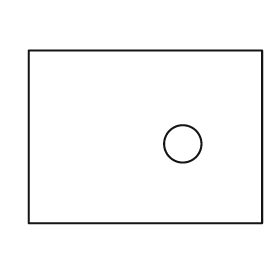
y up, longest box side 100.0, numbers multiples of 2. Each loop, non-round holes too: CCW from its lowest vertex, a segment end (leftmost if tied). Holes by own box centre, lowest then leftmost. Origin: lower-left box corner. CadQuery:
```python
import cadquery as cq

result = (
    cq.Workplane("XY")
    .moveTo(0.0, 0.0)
    .lineTo(100.0, 0.0)
    .lineTo(100.0, 74.0)
    .lineTo(0.0, 74.0)
    .close()
    .moveTo(66.0, 34.0)
    .circle(8.0)
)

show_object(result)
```